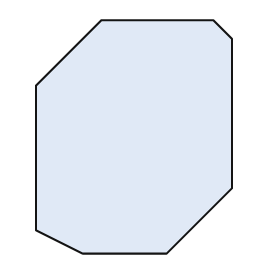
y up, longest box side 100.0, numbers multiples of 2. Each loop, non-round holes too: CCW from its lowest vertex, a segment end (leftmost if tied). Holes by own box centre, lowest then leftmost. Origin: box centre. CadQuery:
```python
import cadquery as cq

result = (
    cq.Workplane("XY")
    .moveTo(-22.0, -50.0)
    .lineTo(14.0, -50.0)
    .lineTo(42.0, -22.0)
    .lineTo(42.0, 42.0)
    .lineTo(34.0, 50.0)
    .lineTo(-14.0, 50.0)
    .lineTo(-42.0, 22.0)
    .lineTo(-42.0, -40.0)
    .close()
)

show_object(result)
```